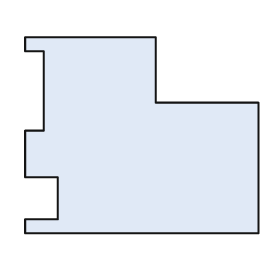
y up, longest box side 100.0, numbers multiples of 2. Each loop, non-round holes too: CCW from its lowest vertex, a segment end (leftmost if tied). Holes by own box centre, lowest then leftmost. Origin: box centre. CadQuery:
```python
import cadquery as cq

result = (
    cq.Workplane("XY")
    .moveTo(-50.0, -42.0)
    .lineTo(50.0, -42.0)
    .lineTo(50.0, 14.0)
    .lineTo(6.0, 14.0)
    .lineTo(6.0, 42.0)
    .lineTo(-50.0, 42.0)
    .lineTo(-50.0, 36.0)
    .lineTo(-42.0, 36.0)
    .lineTo(-42.0, 2.0)
    .lineTo(-50.0, 2.0)
    .lineTo(-50.0, -18.0)
    .lineTo(-36.0, -18.0)
    .lineTo(-36.0, -36.0)
    .lineTo(-50.0, -36.0)
    .close()
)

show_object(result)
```